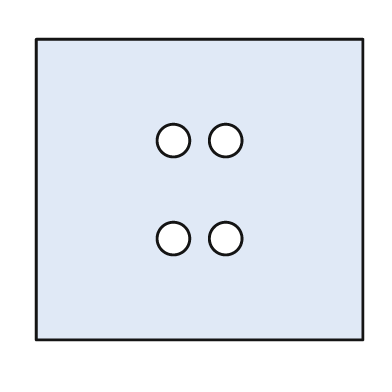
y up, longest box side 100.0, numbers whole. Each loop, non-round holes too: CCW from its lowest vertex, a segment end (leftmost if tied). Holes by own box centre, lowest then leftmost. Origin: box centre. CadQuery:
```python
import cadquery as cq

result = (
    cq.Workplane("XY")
    .moveTo(-50.0, -46.0)
    .lineTo(50.0, -46.0)
    .lineTo(50.0, 46.0)
    .lineTo(-50.0, 46.0)
    .close()
    .moveTo(-8.0, -15.0)
    .circle(5.0)
    .moveTo(8.0, -15.0)
    .circle(5.0)
    .moveTo(-8.0, 15.0)
    .circle(5.0)
    .moveTo(8.0, 15.0)
    .circle(5.0)
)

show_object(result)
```